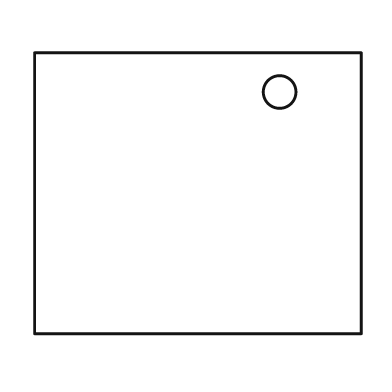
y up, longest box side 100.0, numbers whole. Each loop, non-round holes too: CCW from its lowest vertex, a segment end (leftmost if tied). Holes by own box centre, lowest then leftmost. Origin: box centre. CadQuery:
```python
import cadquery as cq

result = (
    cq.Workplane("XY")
    .moveTo(-50.0, -43.0)
    .lineTo(50.0, -43.0)
    .lineTo(50.0, 43.0)
    .lineTo(-50.0, 43.0)
    .close()
    .moveTo(25.0, 31.0)
    .circle(5.0)
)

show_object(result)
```